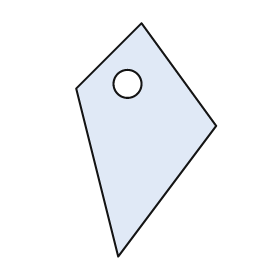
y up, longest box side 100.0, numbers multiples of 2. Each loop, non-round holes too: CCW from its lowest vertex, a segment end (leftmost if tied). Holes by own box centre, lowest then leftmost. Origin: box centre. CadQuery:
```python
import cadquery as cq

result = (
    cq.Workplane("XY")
    .moveTo(-12.0, -50.0)
    .lineTo(30.0, 6.0)
    .lineTo(-2.0, 50.0)
    .lineTo(-30.0, 22.0)
    .close()
    .moveTo(-8.0, 24.0)
    .circle(6.0)
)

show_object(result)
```